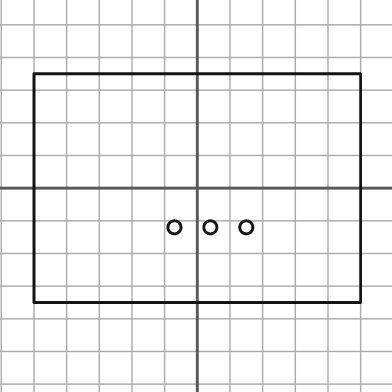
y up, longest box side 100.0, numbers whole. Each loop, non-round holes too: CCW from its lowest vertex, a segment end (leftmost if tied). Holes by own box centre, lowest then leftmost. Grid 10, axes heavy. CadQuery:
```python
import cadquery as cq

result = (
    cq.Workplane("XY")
    .moveTo(-50.0, -35.0)
    .lineTo(50.0, -35.0)
    .lineTo(50.0, 35.0)
    .lineTo(-50.0, 35.0)
    .close()
    .moveTo(-7.0, -12.0)
    .circle(2.0)
    .moveTo(4.0, -12.0)
    .circle(2.0)
    .moveTo(15.0, -12.0)
    .circle(2.0)
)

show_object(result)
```